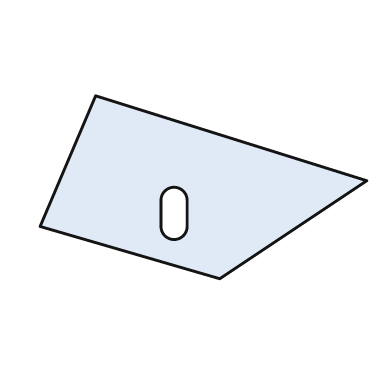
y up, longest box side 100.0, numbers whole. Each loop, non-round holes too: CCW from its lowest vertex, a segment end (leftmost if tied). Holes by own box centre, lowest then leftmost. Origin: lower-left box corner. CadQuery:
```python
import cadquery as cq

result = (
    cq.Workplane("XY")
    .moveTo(55.0, 0.0)
    .lineTo(100.0, 30.0)
    .lineTo(17.0, 56.0)
    .lineTo(0.0, 16.0)
    .close()
    .moveTo(37.0, 16.0)
    .threePointArc((41.0, 12.0), (45.0, 16.0))
    .lineTo(45.0, 24.0)
    .threePointArc((41.0, 28.0), (37.0, 24.0))
    .close()
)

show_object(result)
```